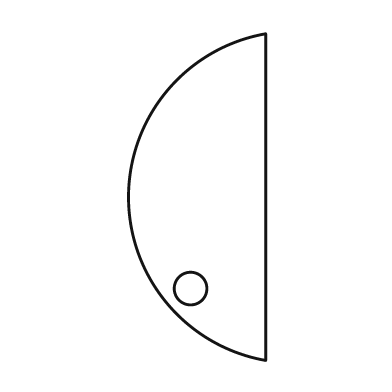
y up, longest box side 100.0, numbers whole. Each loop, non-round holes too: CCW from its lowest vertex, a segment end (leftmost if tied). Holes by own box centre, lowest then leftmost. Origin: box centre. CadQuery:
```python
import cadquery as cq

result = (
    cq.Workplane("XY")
    .moveTo(21.0, -50.0)
    .lineTo(21.0, 50.0)
    .threePointArc((-21.0, 0.0), (21.0, -50.0))
    .close()
    .moveTo(-2.0, -28.0)
    .circle(5.0)
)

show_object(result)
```